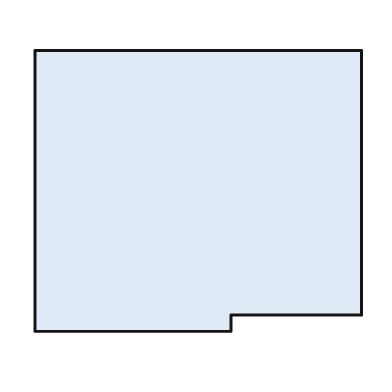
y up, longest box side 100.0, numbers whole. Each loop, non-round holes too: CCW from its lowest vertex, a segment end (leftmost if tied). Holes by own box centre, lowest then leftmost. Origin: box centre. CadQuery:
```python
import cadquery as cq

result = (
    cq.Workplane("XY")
    .moveTo(-50.0, -43.0)
    .lineTo(10.0, -43.0)
    .lineTo(10.0, -38.0)
    .lineTo(50.0, -38.0)
    .lineTo(50.0, 43.0)
    .lineTo(-50.0, 43.0)
    .close()
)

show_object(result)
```